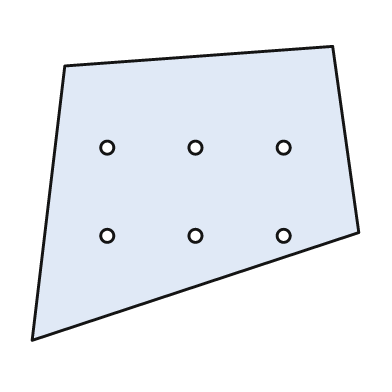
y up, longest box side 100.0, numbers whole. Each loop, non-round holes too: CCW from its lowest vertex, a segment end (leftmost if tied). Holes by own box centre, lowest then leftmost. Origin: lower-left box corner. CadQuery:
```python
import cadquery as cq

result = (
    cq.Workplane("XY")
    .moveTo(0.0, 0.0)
    .lineTo(100.0, 33.0)
    .lineTo(92.0, 90.0)
    .lineTo(10.0, 84.0)
    .close()
    .moveTo(23.0, 32.0)
    .circle(2.0)
    .moveTo(50.0, 32.0)
    .circle(2.0)
    .moveTo(77.0, 32.0)
    .circle(2.0)
    .moveTo(23.0, 59.0)
    .circle(2.0)
    .moveTo(50.0, 59.0)
    .circle(2.0)
    .moveTo(77.0, 59.0)
    .circle(2.0)
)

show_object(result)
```